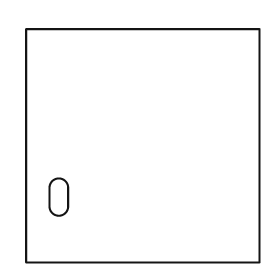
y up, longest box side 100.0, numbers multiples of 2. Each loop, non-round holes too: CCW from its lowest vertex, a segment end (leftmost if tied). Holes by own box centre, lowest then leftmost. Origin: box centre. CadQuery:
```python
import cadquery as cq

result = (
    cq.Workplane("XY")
    .moveTo(-50.0, -50.0)
    .lineTo(50.0, -50.0)
    .lineTo(50.0, 50.0)
    .lineTo(-50.0, 50.0)
    .close()
    .moveTo(-40.0, -26.0)
    .threePointArc((-36.0, -30.0), (-32.0, -26.0))
    .lineTo(-32.0, -18.0)
    .threePointArc((-36.0, -14.0), (-40.0, -18.0))
    .close()
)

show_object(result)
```